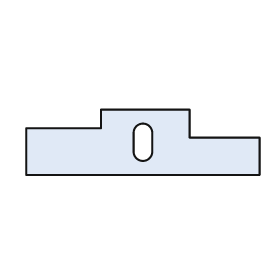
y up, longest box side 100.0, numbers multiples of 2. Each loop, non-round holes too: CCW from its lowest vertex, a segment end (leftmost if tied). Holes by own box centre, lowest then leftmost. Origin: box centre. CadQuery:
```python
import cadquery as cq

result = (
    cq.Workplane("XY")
    .moveTo(-50.0, -14.0)
    .lineTo(50.0, -14.0)
    .lineTo(50.0, 2.0)
    .lineTo(20.0, 2.0)
    .lineTo(20.0, 14.0)
    .lineTo(-18.0, 14.0)
    .lineTo(-18.0, 6.0)
    .lineTo(-50.0, 6.0)
    .close()
    .moveTo(-4.0, -4.0)
    .threePointArc((0.0, -8.0), (4.0, -4.0))
    .lineTo(4.0, 4.0)
    .threePointArc((0.0, 8.0), (-4.0, 4.0))
    .close()
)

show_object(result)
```